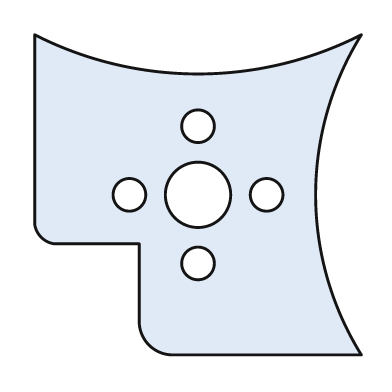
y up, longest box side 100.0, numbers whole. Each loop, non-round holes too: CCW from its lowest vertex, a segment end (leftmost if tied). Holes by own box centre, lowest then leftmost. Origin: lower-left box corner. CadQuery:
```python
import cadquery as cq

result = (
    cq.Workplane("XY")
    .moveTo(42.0, 0.0)
    .lineTo(100.0, 0.0)
    .threePointArc((86.0, 49.0), (100.0, 98.0))
    .threePointArc((50.0, 86.0), (0.0, 98.0))
    .lineTo(0.0, 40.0)
    .threePointArc((2.0, 36.0), (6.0, 34.0))
    .lineTo(32.0, 34.0)
    .lineTo(32.0, 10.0)
    .threePointArc((35.0, 3.0), (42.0, 0.0))
    .close()
    .moveTo(50.0, 28.0)
    .circle(5.0)
    .moveTo(29.0, 49.0)
    .circle(5.0)
    .moveTo(50.0, 49.0)
    .circle(10.0)
    .moveTo(71.0, 49.0)
    .circle(5.0)
    .moveTo(50.0, 70.0)
    .circle(5.0)
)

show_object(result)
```